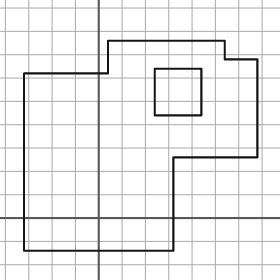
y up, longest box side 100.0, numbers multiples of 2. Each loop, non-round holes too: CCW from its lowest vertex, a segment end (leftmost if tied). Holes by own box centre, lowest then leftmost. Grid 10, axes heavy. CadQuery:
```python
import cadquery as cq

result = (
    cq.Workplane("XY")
    .moveTo(-32.0, -14.0)
    .lineTo(32.0, -14.0)
    .lineTo(32.0, 26.0)
    .lineTo(68.0, 26.0)
    .lineTo(68.0, 68.0)
    .lineTo(54.0, 68.0)
    .lineTo(54.0, 76.0)
    .lineTo(4.0, 76.0)
    .lineTo(4.0, 62.0)
    .lineTo(-32.0, 62.0)
    .close()
    .moveTo(24.0, 44.0)
    .lineTo(44.0, 44.0)
    .lineTo(44.0, 64.0)
    .lineTo(24.0, 64.0)
    .close()
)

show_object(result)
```